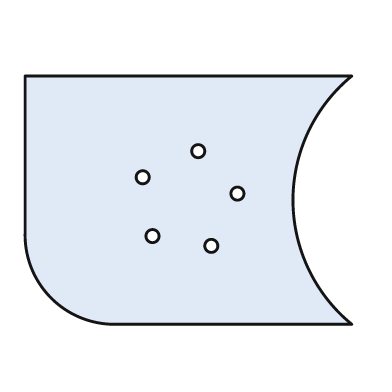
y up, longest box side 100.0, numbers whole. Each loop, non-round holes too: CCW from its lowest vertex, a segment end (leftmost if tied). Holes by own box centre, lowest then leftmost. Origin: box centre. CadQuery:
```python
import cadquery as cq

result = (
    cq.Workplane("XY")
    .moveTo(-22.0, -38.0)
    .lineTo(50.0, -38.0)
    .threePointArc((32.0, 0.0), (50.0, 38.0))
    .lineTo(-50.0, 38.0)
    .lineTo(-50.0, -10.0)
    .threePointArc((-42.0, -30.0), (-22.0, -38.0))
    .close()
    .moveTo(7.0, -14.0)
    .circle(2.0)
    .moveTo(-11.0, -11.0)
    .circle(2.0)
    .moveTo(15.0, 2.0)
    .circle(2.0)
    .moveTo(-14.0, 7.0)
    .circle(2.0)
    .moveTo(3.0, 15.0)
    .circle(2.0)
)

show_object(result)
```